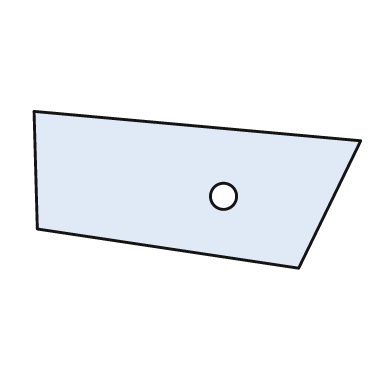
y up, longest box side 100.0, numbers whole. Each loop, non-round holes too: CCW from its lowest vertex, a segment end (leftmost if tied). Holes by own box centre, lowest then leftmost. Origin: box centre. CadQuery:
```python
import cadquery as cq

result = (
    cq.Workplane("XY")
    .moveTo(31.0, -24.0)
    .lineTo(50.0, 15.0)
    .lineTo(-50.0, 24.0)
    .lineTo(-49.0, -12.0)
    .close()
    .moveTo(8.0, -2.0)
    .circle(4.0)
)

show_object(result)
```